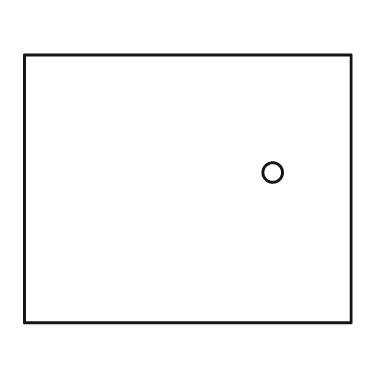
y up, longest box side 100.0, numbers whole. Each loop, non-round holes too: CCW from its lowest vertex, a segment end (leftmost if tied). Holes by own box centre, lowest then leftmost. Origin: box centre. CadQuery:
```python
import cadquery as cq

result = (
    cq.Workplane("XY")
    .moveTo(-50.0, -41.0)
    .lineTo(50.0, -41.0)
    .lineTo(50.0, 41.0)
    .lineTo(-50.0, 41.0)
    .close()
    .moveTo(26.0, 5.0)
    .circle(3.0)
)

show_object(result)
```